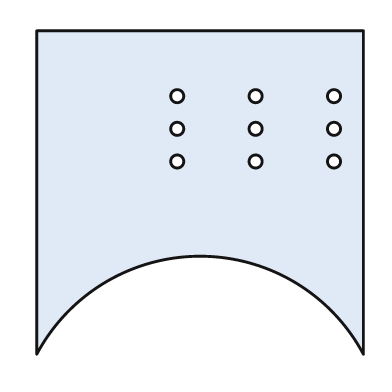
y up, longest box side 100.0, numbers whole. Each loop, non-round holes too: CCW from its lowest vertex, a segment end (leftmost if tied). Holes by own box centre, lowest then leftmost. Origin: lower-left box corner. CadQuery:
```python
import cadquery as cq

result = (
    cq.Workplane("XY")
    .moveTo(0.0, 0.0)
    .threePointArc((50.0, 30.0), (100.0, 0.0))
    .lineTo(100.0, 99.0)
    .lineTo(0.0, 99.0)
    .close()
    .moveTo(43.0, 59.0)
    .circle(2.0)
    .moveTo(67.0, 59.0)
    .circle(2.0)
    .moveTo(91.0, 59.0)
    .circle(2.0)
    .moveTo(43.0, 69.0)
    .circle(2.0)
    .moveTo(67.0, 69.0)
    .circle(2.0)
    .moveTo(91.0, 69.0)
    .circle(2.0)
    .moveTo(43.0, 79.0)
    .circle(2.0)
    .moveTo(67.0, 79.0)
    .circle(2.0)
    .moveTo(91.0, 79.0)
    .circle(2.0)
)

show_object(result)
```